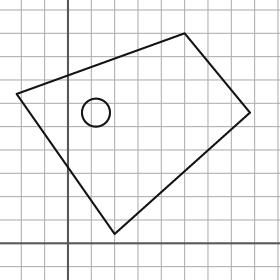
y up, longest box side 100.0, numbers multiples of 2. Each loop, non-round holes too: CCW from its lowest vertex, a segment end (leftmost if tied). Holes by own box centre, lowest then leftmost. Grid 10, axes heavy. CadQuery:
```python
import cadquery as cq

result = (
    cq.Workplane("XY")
    .moveTo(20.0, 4.0)
    .lineTo(78.0, 56.0)
    .lineTo(50.0, 90.0)
    .lineTo(-22.0, 64.0)
    .close()
    .moveTo(12.0, 56.0)
    .circle(6.0)
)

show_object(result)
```